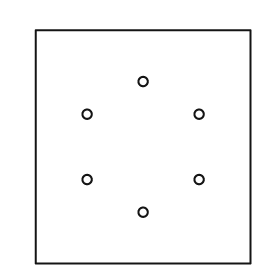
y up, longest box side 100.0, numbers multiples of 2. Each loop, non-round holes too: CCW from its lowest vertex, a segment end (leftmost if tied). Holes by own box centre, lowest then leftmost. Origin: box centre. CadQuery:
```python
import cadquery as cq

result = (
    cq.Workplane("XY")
    .moveTo(-46.0, -50.0)
    .lineTo(46.0, -50.0)
    .lineTo(46.0, 50.0)
    .lineTo(-46.0, 50.0)
    .close()
    .moveTo(0.0, -28.0)
    .circle(2.0)
    .moveTo(-24.0, -14.0)
    .circle(2.0)
    .moveTo(24.0, -14.0)
    .circle(2.0)
    .moveTo(-24.0, 14.0)
    .circle(2.0)
    .moveTo(24.0, 14.0)
    .circle(2.0)
    .moveTo(0.0, 28.0)
    .circle(2.0)
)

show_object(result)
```